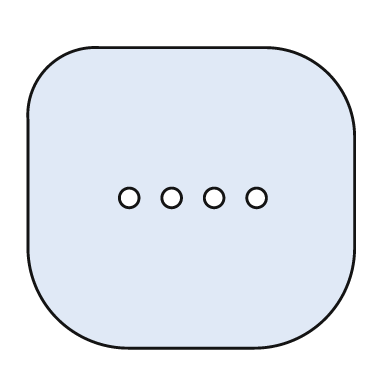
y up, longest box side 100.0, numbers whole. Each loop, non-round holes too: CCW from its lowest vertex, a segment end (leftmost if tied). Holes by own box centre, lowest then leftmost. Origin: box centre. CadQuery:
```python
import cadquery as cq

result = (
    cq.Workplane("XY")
    .moveTo(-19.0, -46.0)
    .lineTo(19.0, -46.0)
    .threePointArc((41.0, -37.0), (50.0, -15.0))
    .lineTo(50.0, 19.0)
    .threePointArc((42.0, 38.0), (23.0, 46.0))
    .lineTo(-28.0, 46.0)
    .threePointArc((-44.0, 40.0), (-50.0, 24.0))
    .lineTo(-50.0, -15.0)
    .threePointArc((-41.0, -37.0), (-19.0, -46.0))
    .close()
    .moveTo(-19.0, 0.0)
    .circle(3.0)
    .moveTo(-6.0, 0.0)
    .circle(3.0)
    .moveTo(7.0, 0.0)
    .circle(3.0)
    .moveTo(20.0, 0.0)
    .circle(3.0)
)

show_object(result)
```